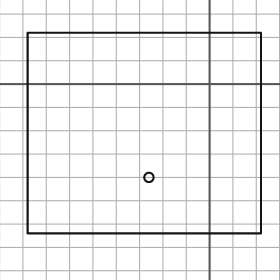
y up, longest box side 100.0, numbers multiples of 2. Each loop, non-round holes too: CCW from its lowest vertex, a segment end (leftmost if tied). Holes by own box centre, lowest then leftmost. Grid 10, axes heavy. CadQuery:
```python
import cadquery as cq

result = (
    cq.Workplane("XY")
    .moveTo(-78.0, -64.0)
    .lineTo(22.0, -64.0)
    .lineTo(22.0, 22.0)
    .lineTo(-78.0, 22.0)
    .close()
    .moveTo(-26.0, -40.0)
    .circle(2.0)
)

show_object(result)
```